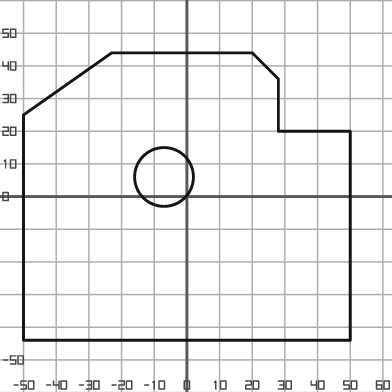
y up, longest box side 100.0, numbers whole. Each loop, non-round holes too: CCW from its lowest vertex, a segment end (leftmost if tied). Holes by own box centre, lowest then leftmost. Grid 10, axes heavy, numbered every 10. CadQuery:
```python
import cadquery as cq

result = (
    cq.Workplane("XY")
    .moveTo(-50.0, -44.0)
    .lineTo(50.0, -44.0)
    .lineTo(50.0, 20.0)
    .lineTo(28.0, 20.0)
    .lineTo(28.0, 36.0)
    .lineTo(20.0, 44.0)
    .lineTo(-23.0, 44.0)
    .lineTo(-50.0, 25.0)
    .close()
    .moveTo(-7.0, 6.0)
    .circle(9.0)
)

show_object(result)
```